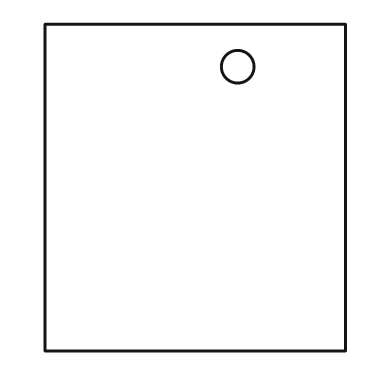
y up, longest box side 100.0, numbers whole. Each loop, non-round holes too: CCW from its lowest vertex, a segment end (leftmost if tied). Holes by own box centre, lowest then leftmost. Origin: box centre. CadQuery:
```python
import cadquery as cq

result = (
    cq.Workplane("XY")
    .moveTo(-46.0, -50.0)
    .lineTo(46.0, -50.0)
    .lineTo(46.0, 50.0)
    .lineTo(-46.0, 50.0)
    .close()
    .moveTo(13.0, 37.0)
    .circle(5.0)
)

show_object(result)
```